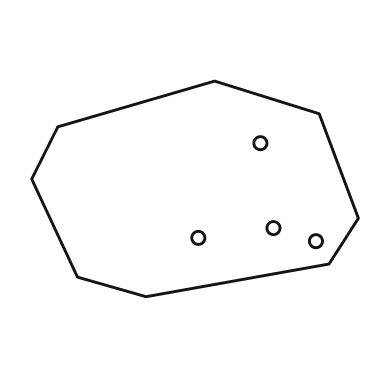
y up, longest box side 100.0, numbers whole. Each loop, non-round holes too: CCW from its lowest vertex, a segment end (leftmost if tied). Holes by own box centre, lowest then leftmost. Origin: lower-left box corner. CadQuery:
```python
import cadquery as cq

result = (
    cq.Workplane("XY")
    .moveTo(35.0, 0.0)
    .lineTo(91.0, 10.0)
    .lineTo(100.0, 24.0)
    .lineTo(88.0, 56.0)
    .lineTo(56.0, 66.0)
    .lineTo(8.0, 52.0)
    .lineTo(0.0, 36.0)
    .lineTo(14.0, 6.0)
    .close()
    .moveTo(87.0, 17.0)
    .circle(2.0)
    .moveTo(51.0, 18.0)
    .circle(2.0)
    .moveTo(74.0, 21.0)
    .circle(2.0)
    .moveTo(70.0, 47.0)
    .circle(2.0)
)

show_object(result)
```